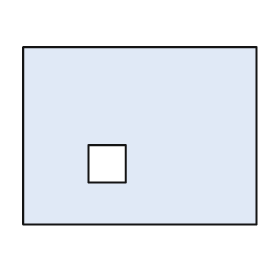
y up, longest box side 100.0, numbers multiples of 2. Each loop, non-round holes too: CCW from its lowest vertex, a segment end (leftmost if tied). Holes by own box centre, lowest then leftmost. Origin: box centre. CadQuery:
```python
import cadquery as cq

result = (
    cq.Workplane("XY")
    .moveTo(-50.0, -38.0)
    .lineTo(50.0, -38.0)
    .lineTo(50.0, 38.0)
    .lineTo(-50.0, 38.0)
    .close()
    .moveTo(-22.0, -20.0)
    .lineTo(-6.0, -20.0)
    .lineTo(-6.0, -4.0)
    .lineTo(-22.0, -4.0)
    .close()
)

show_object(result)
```